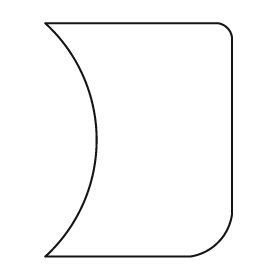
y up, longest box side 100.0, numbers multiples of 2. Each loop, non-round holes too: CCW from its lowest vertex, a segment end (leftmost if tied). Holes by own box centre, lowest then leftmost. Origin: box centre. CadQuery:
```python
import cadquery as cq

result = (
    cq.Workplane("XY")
    .moveTo(-40.0, -50.0)
    .lineTo(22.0, -50.0)
    .threePointArc((34.0, -44.0), (40.0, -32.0))
    .lineTo(40.0, 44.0)
    .threePointArc((38.0, 48.0), (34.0, 50.0))
    .lineTo(-40.0, 50.0)
    .threePointArc((-18.0, 0.0), (-40.0, -50.0))
    .close()
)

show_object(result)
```